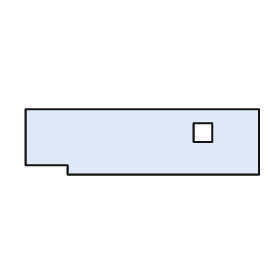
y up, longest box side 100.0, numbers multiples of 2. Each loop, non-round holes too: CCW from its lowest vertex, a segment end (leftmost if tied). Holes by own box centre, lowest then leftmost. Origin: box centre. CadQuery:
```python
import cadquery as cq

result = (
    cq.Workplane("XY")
    .moveTo(-32.0, -14.0)
    .lineTo(50.0, -14.0)
    .lineTo(50.0, 14.0)
    .lineTo(-50.0, 14.0)
    .lineTo(-50.0, -10.0)
    .lineTo(-32.0, -10.0)
    .close()
    .moveTo(22.0, 0.0)
    .lineTo(30.0, 0.0)
    .lineTo(30.0, 8.0)
    .lineTo(22.0, 8.0)
    .close()
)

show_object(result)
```